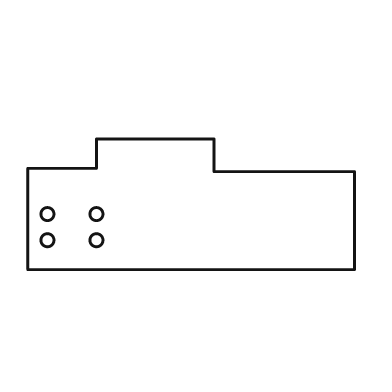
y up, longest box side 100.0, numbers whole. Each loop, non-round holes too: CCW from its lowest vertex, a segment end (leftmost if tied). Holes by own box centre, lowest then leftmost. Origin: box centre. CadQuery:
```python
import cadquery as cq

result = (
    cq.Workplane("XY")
    .moveTo(-50.0, -20.0)
    .lineTo(50.0, -20.0)
    .lineTo(50.0, 10.0)
    .lineTo(7.0, 10.0)
    .lineTo(7.0, 20.0)
    .lineTo(-29.0, 20.0)
    .lineTo(-29.0, 11.0)
    .lineTo(-50.0, 11.0)
    .close()
    .moveTo(-44.0, -11.0)
    .circle(2.0)
    .moveTo(-29.0, -11.0)
    .circle(2.0)
    .moveTo(-44.0, -3.0)
    .circle(2.0)
    .moveTo(-29.0, -3.0)
    .circle(2.0)
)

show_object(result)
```